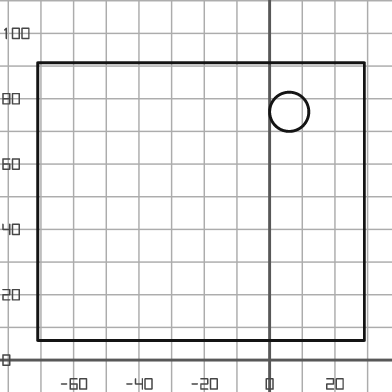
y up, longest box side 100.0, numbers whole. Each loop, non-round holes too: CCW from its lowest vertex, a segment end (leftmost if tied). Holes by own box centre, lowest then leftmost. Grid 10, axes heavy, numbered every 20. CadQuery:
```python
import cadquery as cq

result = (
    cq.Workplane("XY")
    .moveTo(-71.0, 6.0)
    .lineTo(29.0, 6.0)
    .lineTo(29.0, 91.0)
    .lineTo(-71.0, 91.0)
    .close()
    .moveTo(6.0, 76.0)
    .circle(6.0)
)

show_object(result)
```